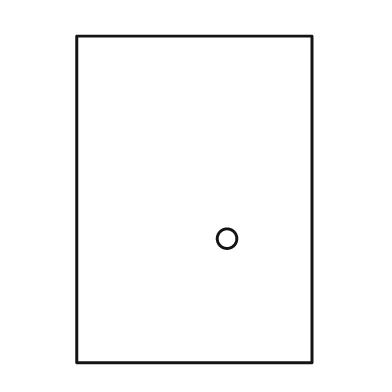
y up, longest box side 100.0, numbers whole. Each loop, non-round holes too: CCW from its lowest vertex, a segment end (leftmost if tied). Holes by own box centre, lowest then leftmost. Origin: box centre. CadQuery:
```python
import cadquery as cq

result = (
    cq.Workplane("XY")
    .moveTo(-36.0, -50.0)
    .lineTo(36.0, -50.0)
    .lineTo(36.0, 50.0)
    .lineTo(-36.0, 50.0)
    .close()
    .moveTo(10.0, -12.0)
    .circle(3.0)
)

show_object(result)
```